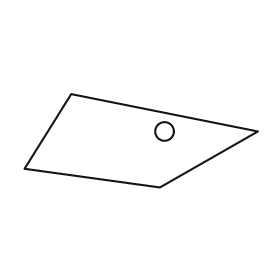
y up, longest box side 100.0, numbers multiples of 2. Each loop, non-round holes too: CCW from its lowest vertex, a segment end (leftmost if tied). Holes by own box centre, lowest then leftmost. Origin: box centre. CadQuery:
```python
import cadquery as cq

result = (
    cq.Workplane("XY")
    .moveTo(8.0, -20.0)
    .lineTo(50.0, 4.0)
    .lineTo(-30.0, 20.0)
    .lineTo(-50.0, -12.0)
    .close()
    .moveTo(10.0, 4.0)
    .circle(4.0)
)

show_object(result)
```